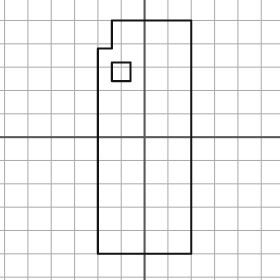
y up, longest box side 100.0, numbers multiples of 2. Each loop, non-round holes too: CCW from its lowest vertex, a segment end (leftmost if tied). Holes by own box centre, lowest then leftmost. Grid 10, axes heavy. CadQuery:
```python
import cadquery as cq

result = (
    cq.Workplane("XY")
    .moveTo(-20.0, -50.0)
    .lineTo(20.0, -50.0)
    .lineTo(20.0, 50.0)
    .lineTo(-14.0, 50.0)
    .lineTo(-14.0, 38.0)
    .lineTo(-20.0, 38.0)
    .close()
    .moveTo(-14.0, 24.0)
    .lineTo(-6.0, 24.0)
    .lineTo(-6.0, 32.0)
    .lineTo(-14.0, 32.0)
    .close()
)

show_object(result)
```